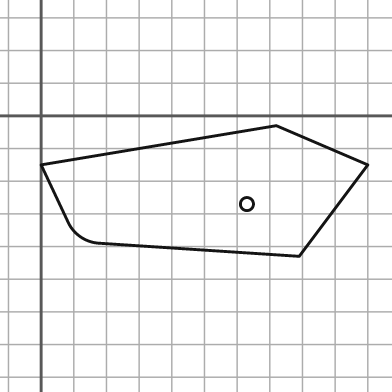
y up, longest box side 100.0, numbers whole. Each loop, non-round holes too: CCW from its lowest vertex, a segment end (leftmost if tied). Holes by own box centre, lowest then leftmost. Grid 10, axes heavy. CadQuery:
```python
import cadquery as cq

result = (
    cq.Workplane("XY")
    .moveTo(79.0, -43.0)
    .lineTo(100.0, -15.0)
    .lineTo(72.0, -3.0)
    .lineTo(0.0, -15.0)
    .lineTo(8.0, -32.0)
    .threePointArc((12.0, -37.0), (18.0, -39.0))
    .close()
    .moveTo(63.0, -27.0)
    .circle(2.0)
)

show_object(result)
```